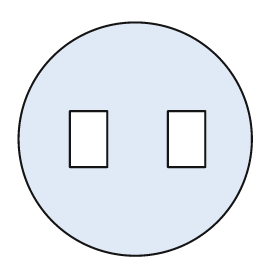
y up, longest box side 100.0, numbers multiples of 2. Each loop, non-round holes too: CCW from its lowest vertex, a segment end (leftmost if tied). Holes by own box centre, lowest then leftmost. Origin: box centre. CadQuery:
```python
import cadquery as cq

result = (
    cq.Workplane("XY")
    .moveTo(0.0, 0.0)
    .circle(50.0)
    .moveTo(-28.0, -12.0)
    .lineTo(-12.0, -12.0)
    .lineTo(-12.0, 12.0)
    .lineTo(-28.0, 12.0)
    .close()
    .moveTo(14.0, -12.0)
    .lineTo(30.0, -12.0)
    .lineTo(30.0, 12.0)
    .lineTo(14.0, 12.0)
    .close()
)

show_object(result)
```